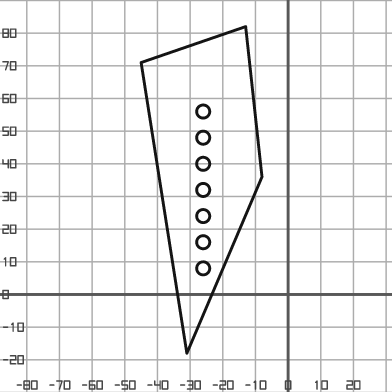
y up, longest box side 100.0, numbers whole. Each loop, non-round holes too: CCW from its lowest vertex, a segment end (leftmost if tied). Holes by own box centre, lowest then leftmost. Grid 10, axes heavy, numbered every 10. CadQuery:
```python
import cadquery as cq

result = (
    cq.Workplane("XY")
    .moveTo(-31.0, -18.0)
    .lineTo(-8.0, 36.0)
    .lineTo(-13.0, 82.0)
    .lineTo(-45.0, 71.0)
    .close()
    .moveTo(-26.0, 8.0)
    .circle(2.0)
    .moveTo(-26.0, 16.0)
    .circle(2.0)
    .moveTo(-26.0, 24.0)
    .circle(2.0)
    .moveTo(-26.0, 32.0)
    .circle(2.0)
    .moveTo(-26.0, 40.0)
    .circle(2.0)
    .moveTo(-26.0, 48.0)
    .circle(2.0)
    .moveTo(-26.0, 56.0)
    .circle(2.0)
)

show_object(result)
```